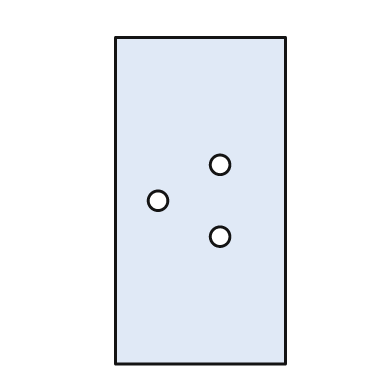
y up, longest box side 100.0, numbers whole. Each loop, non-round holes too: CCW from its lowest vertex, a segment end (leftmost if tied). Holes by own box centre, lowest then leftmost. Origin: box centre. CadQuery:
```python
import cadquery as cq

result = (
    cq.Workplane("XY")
    .moveTo(-26.0, -50.0)
    .lineTo(26.0, -50.0)
    .lineTo(26.0, 50.0)
    .lineTo(-26.0, 50.0)
    .close()
    .moveTo(6.0, -11.0)
    .circle(3.0)
    .moveTo(-13.0, 0.0)
    .circle(3.0)
    .moveTo(6.0, 11.0)
    .circle(3.0)
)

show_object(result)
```